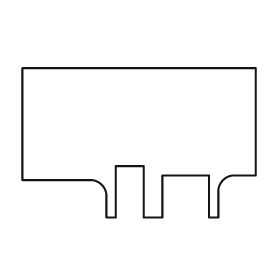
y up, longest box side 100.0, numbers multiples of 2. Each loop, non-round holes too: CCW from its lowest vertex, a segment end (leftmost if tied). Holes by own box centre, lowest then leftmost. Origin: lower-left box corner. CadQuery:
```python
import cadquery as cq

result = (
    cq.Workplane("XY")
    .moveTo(36.0, 0.0)
    .lineTo(40.0, 0.0)
    .lineTo(40.0, 22.0)
    .lineTo(52.0, 22.0)
    .lineTo(52.0, 0.0)
    .lineTo(60.0, 0.0)
    .lineTo(60.0, 18.0)
    .lineTo(80.0, 18.0)
    .lineTo(80.0, 0.0)
    .lineTo(84.0, 0.0)
    .lineTo(84.0, 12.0)
    .threePointArc((86.0, 16.0), (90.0, 18.0))
    .lineTo(100.0, 18.0)
    .lineTo(100.0, 64.0)
    .lineTo(0.0, 64.0)
    .lineTo(0.0, 16.0)
    .lineTo(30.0, 16.0)
    .threePointArc((34.0, 14.0), (36.0, 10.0))
    .close()
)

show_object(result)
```